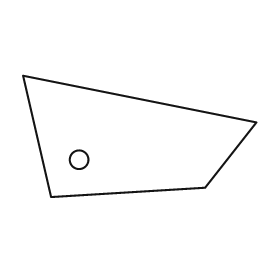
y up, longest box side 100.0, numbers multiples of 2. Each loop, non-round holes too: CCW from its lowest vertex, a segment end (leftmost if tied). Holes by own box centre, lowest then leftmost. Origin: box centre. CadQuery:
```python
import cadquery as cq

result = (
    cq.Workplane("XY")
    .moveTo(-38.0, -26.0)
    .lineTo(28.0, -22.0)
    .lineTo(50.0, 6.0)
    .lineTo(-50.0, 26.0)
    .close()
    .moveTo(-26.0, -10.0)
    .circle(4.0)
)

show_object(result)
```